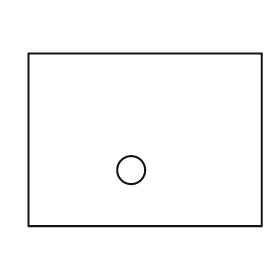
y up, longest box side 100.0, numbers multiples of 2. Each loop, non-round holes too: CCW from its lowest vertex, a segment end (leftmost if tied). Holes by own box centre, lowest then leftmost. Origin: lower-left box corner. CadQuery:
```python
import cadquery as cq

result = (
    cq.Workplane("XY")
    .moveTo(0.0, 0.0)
    .lineTo(100.0, 0.0)
    .lineTo(100.0, 74.0)
    .lineTo(0.0, 74.0)
    .close()
    .moveTo(44.0, 24.0)
    .circle(6.0)
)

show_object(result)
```